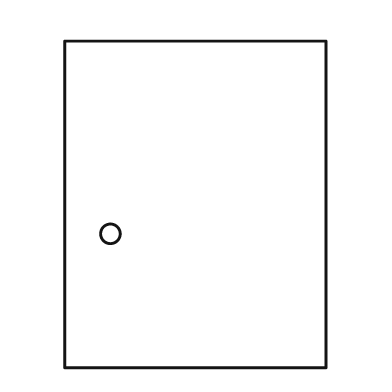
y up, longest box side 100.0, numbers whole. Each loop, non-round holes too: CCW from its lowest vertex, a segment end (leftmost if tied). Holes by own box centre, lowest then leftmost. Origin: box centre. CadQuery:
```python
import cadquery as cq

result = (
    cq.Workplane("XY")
    .moveTo(-40.0, -50.0)
    .lineTo(40.0, -50.0)
    .lineTo(40.0, 50.0)
    .lineTo(-40.0, 50.0)
    .close()
    .moveTo(-26.0, -9.0)
    .circle(3.0)
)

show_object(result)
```